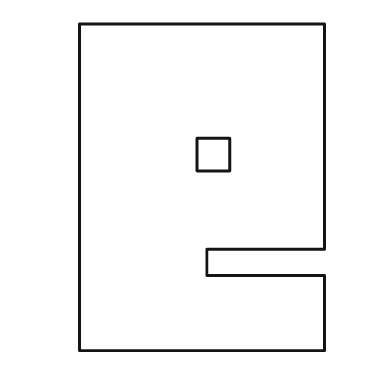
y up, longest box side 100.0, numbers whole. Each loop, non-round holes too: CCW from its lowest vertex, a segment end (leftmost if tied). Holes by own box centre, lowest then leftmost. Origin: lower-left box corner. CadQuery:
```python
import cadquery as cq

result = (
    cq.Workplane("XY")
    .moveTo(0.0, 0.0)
    .lineTo(75.0, 0.0)
    .lineTo(75.0, 23.0)
    .lineTo(39.0, 23.0)
    .lineTo(39.0, 31.0)
    .lineTo(75.0, 31.0)
    .lineTo(75.0, 100.0)
    .lineTo(0.0, 100.0)
    .close()
    .moveTo(36.0, 55.0)
    .lineTo(46.0, 55.0)
    .lineTo(46.0, 65.0)
    .lineTo(36.0, 65.0)
    .close()
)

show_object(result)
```